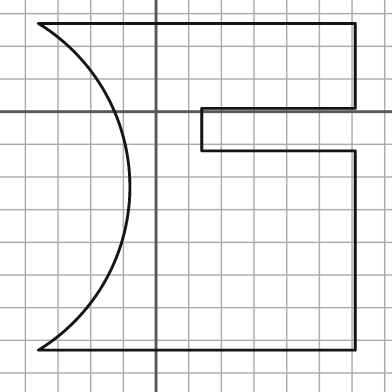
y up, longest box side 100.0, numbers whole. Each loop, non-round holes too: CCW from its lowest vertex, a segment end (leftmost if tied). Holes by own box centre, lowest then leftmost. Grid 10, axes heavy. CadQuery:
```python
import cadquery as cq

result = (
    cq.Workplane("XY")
    .moveTo(-36.0, -73.0)
    .lineTo(61.0, -73.0)
    .lineTo(61.0, -12.0)
    .lineTo(14.0, -12.0)
    .lineTo(14.0, 1.0)
    .lineTo(61.0, 1.0)
    .lineTo(61.0, 27.0)
    .lineTo(-36.0, 27.0)
    .threePointArc((-8.0, -23.0), (-36.0, -73.0))
    .close()
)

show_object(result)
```